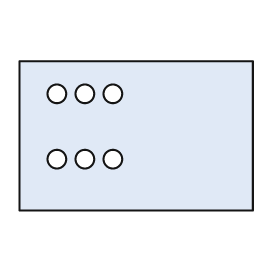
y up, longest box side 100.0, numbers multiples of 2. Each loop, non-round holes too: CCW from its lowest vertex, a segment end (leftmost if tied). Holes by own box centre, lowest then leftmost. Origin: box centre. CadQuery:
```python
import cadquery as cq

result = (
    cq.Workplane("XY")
    .moveTo(-50.0, -32.0)
    .lineTo(50.0, -32.0)
    .lineTo(50.0, 32.0)
    .lineTo(-50.0, 32.0)
    .close()
    .moveTo(-34.0, -10.0)
    .circle(4.0)
    .moveTo(-22.0, -10.0)
    .circle(4.0)
    .moveTo(-10.0, -10.0)
    .circle(4.0)
    .moveTo(-34.0, 18.0)
    .circle(4.0)
    .moveTo(-22.0, 18.0)
    .circle(4.0)
    .moveTo(-10.0, 18.0)
    .circle(4.0)
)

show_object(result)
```